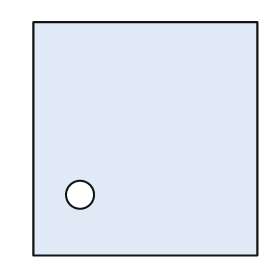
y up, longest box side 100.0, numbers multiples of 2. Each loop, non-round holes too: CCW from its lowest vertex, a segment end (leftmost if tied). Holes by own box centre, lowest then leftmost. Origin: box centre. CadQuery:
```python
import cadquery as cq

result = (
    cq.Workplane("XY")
    .moveTo(-48.0, -50.0)
    .lineTo(48.0, -50.0)
    .lineTo(48.0, 50.0)
    .lineTo(-48.0, 50.0)
    .close()
    .moveTo(-28.0, -24.0)
    .circle(6.0)
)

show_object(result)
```